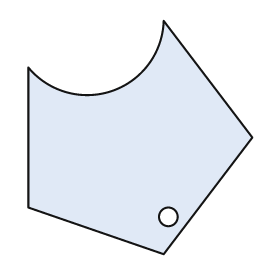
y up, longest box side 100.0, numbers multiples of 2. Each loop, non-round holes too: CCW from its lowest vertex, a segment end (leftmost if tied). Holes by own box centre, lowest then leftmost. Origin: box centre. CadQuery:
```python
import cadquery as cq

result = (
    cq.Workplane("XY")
    .moveTo(10.0, -50.0)
    .lineTo(48.0, 0.0)
    .lineTo(10.0, 50.0)
    .threePointArc((-12.0, 20.0), (-48.0, 30.0))
    .lineTo(-48.0, -30.0)
    .close()
    .moveTo(12.0, -34.0)
    .circle(4.0)
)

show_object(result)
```